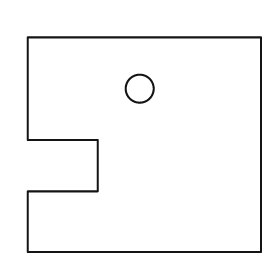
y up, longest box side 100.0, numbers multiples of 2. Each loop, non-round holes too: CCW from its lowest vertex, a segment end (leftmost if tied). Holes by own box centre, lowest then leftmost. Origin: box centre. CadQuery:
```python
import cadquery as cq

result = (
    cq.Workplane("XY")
    .moveTo(-50.0, -46.0)
    .lineTo(50.0, -46.0)
    .lineTo(50.0, 46.0)
    .lineTo(-50.0, 46.0)
    .lineTo(-50.0, 2.0)
    .lineTo(-20.0, 2.0)
    .lineTo(-20.0, -20.0)
    .lineTo(-50.0, -20.0)
    .close()
    .moveTo(-2.0, 24.0)
    .circle(6.0)
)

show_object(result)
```